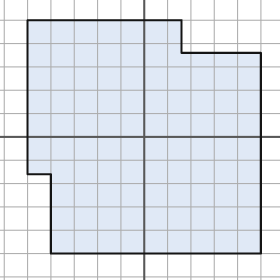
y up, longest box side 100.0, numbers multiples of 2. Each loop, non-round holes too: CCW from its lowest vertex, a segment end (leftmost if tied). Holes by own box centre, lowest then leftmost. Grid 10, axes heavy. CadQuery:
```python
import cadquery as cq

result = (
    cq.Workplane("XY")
    .moveTo(-40.0, -50.0)
    .lineTo(50.0, -50.0)
    .lineTo(50.0, 36.0)
    .lineTo(16.0, 36.0)
    .lineTo(16.0, 50.0)
    .lineTo(-50.0, 50.0)
    .lineTo(-50.0, -16.0)
    .lineTo(-40.0, -16.0)
    .close()
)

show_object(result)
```